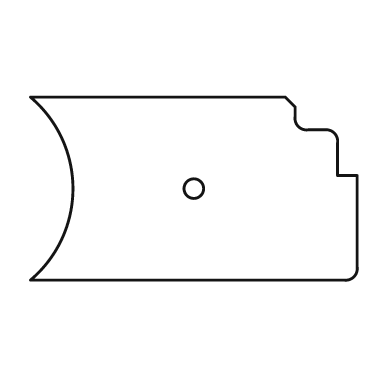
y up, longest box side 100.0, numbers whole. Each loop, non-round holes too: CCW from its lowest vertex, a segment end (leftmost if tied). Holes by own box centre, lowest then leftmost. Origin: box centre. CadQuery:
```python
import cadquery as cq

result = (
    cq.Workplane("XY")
    .moveTo(-50.0, -28.0)
    .lineTo(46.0, -28.0)
    .threePointArc((49.0, -27.0), (50.0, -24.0))
    .lineTo(50.0, 4.0)
    .lineTo(44.0, 4.0)
    .lineTo(44.0, 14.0)
    .threePointArc((43.0, 17.0), (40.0, 18.0))
    .lineTo(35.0, 18.0)
    .threePointArc((32.0, 19.0), (31.0, 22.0))
    .lineTo(31.0, 25.0)
    .lineTo(28.0, 28.0)
    .lineTo(-50.0, 28.0)
    .threePointArc((-37.0, 0.0), (-50.0, -28.0))
    .close()
    .moveTo(0.0, 0.0)
    .circle(3.0)
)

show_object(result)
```